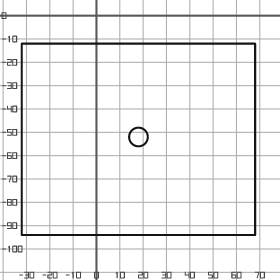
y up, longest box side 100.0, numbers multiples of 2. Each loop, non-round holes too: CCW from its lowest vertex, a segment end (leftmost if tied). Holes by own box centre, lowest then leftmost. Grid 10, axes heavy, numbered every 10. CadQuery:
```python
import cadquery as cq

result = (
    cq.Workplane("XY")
    .moveTo(-32.0, -94.0)
    .lineTo(68.0, -94.0)
    .lineTo(68.0, -12.0)
    .lineTo(-32.0, -12.0)
    .close()
    .moveTo(18.0, -52.0)
    .circle(4.0)
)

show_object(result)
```